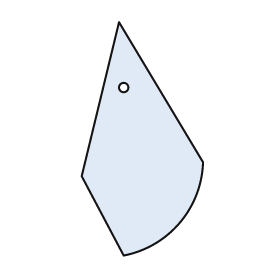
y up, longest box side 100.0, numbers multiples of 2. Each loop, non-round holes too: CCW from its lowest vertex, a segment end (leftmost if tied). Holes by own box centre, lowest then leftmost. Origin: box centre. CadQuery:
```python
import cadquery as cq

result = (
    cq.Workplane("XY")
    .moveTo(-8.0, -50.0)
    .threePointArc((16.0, -36.0), (26.0, -10.0))
    .lineTo(-10.0, 50.0)
    .lineTo(-26.0, -16.0)
    .close()
    .moveTo(-8.0, 22.0)
    .circle(2.0)
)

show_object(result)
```